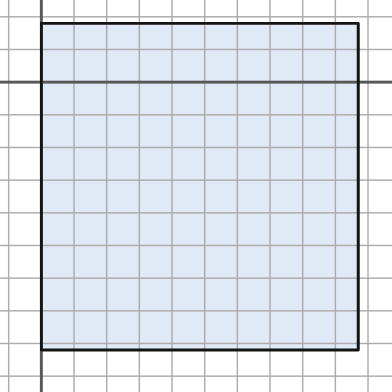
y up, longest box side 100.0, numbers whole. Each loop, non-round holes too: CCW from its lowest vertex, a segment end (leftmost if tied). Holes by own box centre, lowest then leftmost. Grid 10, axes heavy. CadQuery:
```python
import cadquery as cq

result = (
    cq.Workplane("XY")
    .moveTo(0.0, -82.0)
    .lineTo(97.0, -82.0)
    .lineTo(97.0, 18.0)
    .lineTo(0.0, 18.0)
    .close()
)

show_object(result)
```